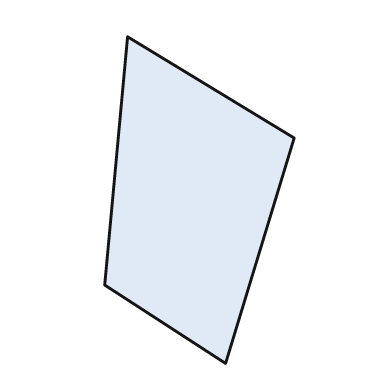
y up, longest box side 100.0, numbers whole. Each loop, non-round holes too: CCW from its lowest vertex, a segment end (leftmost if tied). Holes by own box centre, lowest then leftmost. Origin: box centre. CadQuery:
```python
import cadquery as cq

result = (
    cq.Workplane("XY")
    .moveTo(8.0, -50.0)
    .lineTo(29.0, 19.0)
    .lineTo(-22.0, 50.0)
    .lineTo(-29.0, -26.0)
    .close()
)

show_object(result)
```